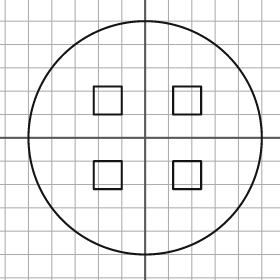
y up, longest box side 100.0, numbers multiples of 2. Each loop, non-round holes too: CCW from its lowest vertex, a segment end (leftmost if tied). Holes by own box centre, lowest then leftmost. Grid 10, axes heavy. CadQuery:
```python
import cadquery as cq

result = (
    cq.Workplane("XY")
    .moveTo(0.0, 0.0)
    .circle(50.0)
    .moveTo(-22.0, -22.0)
    .lineTo(-10.0, -22.0)
    .lineTo(-10.0, -10.0)
    .lineTo(-22.0, -10.0)
    .close()
    .moveTo(12.0, -22.0)
    .lineTo(24.0, -22.0)
    .lineTo(24.0, -10.0)
    .lineTo(12.0, -10.0)
    .close()
    .moveTo(-22.0, 10.0)
    .lineTo(-10.0, 10.0)
    .lineTo(-10.0, 22.0)
    .lineTo(-22.0, 22.0)
    .close()
    .moveTo(12.0, 10.0)
    .lineTo(24.0, 10.0)
    .lineTo(24.0, 22.0)
    .lineTo(12.0, 22.0)
    .close()
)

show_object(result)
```